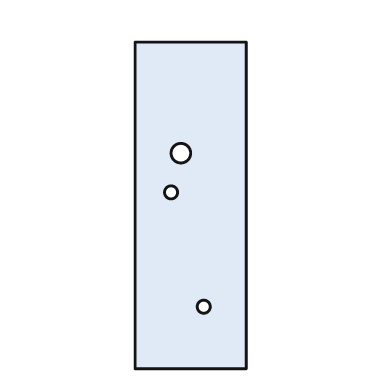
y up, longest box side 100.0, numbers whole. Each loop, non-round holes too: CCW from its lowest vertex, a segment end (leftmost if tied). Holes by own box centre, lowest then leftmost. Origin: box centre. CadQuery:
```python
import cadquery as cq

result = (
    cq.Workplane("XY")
    .moveTo(-17.0, -50.0)
    .lineTo(17.0, -50.0)
    .lineTo(17.0, 50.0)
    .lineTo(-17.0, 50.0)
    .close()
    .moveTo(4.0, -31.0)
    .circle(2.0)
    .moveTo(-6.0, 4.0)
    .circle(2.0)
    .moveTo(-3.0, 16.0)
    .circle(3.0)
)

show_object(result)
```